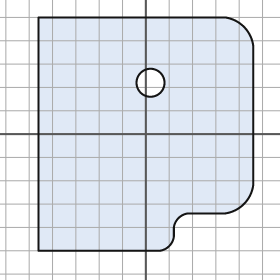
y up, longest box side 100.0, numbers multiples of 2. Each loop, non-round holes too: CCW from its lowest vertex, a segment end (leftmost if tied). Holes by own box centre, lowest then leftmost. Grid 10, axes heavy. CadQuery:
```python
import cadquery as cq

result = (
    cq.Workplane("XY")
    .moveTo(-46.0, -50.0)
    .lineTo(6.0, -50.0)
    .threePointArc((10.0, -48.0), (12.0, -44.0))
    .lineTo(12.0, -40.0)
    .threePointArc((14.0, -36.0), (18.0, -34.0))
    .lineTo(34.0, -34.0)
    .threePointArc((42.0, -30.0), (46.0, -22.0))
    .lineTo(46.0, 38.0)
    .threePointArc((42.0, 46.0), (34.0, 50.0))
    .lineTo(-46.0, 50.0)
    .close()
    .moveTo(2.0, 22.0)
    .circle(6.0)
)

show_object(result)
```